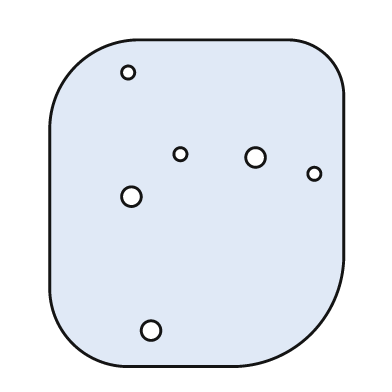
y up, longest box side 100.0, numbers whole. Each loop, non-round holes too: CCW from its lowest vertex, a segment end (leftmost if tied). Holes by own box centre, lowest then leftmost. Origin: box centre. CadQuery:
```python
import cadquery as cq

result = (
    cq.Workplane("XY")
    .moveTo(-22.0, -50.0)
    .lineTo(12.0, -50.0)
    .threePointArc((35.0, -40.0), (45.0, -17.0))
    .lineTo(45.0, 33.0)
    .threePointArc((40.0, 45.0), (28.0, 50.0))
    .lineTo(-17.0, 50.0)
    .threePointArc((-37.0, 42.0), (-45.0, 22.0))
    .lineTo(-45.0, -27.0)
    .threePointArc((-38.0, -43.0), (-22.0, -50.0))
    .close()
    .moveTo(-14.0, -39.0)
    .circle(3.0)
    .moveTo(-20.0, 2.0)
    .circle(3.0)
    .moveTo(36.0, 9.0)
    .circle(2.0)
    .moveTo(18.0, 14.0)
    .circle(3.0)
    .moveTo(-5.0, 15.0)
    .circle(2.0)
    .moveTo(-21.0, 40.0)
    .circle(2.0)
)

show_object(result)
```